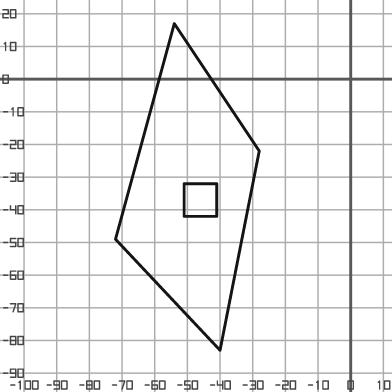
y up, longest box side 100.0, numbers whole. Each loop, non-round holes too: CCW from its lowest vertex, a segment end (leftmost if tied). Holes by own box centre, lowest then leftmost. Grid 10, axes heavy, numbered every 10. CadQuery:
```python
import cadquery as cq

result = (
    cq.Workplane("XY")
    .moveTo(-40.0, -83.0)
    .lineTo(-28.0, -22.0)
    .lineTo(-54.0, 17.0)
    .lineTo(-72.0, -49.0)
    .close()
    .moveTo(-51.0, -42.0)
    .lineTo(-41.0, -42.0)
    .lineTo(-41.0, -32.0)
    .lineTo(-51.0, -32.0)
    .close()
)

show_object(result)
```